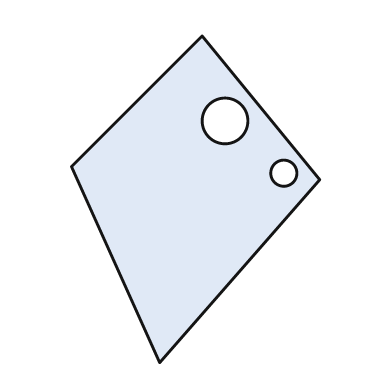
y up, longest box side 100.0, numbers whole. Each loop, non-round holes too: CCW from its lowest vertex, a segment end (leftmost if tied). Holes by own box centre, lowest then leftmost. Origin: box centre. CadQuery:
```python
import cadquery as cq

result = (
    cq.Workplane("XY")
    .moveTo(-11.0, -50.0)
    .lineTo(38.0, 6.0)
    .lineTo(2.0, 50.0)
    .lineTo(-38.0, 10.0)
    .close()
    .moveTo(27.0, 8.0)
    .circle(4.0)
    .moveTo(9.0, 24.0)
    .circle(7.0)
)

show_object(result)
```